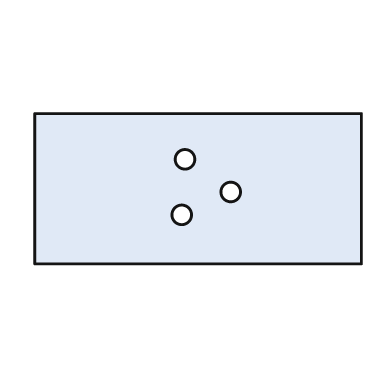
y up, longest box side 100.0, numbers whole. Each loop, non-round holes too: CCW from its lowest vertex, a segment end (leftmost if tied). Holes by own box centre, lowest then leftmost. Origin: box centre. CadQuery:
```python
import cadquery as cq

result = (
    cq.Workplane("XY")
    .moveTo(-50.0, -23.0)
    .lineTo(50.0, -23.0)
    .lineTo(50.0, 23.0)
    .lineTo(-50.0, 23.0)
    .close()
    .moveTo(-5.0, -8.0)
    .circle(3.0)
    .moveTo(10.0, -1.0)
    .circle(3.0)
    .moveTo(-4.0, 9.0)
    .circle(3.0)
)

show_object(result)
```